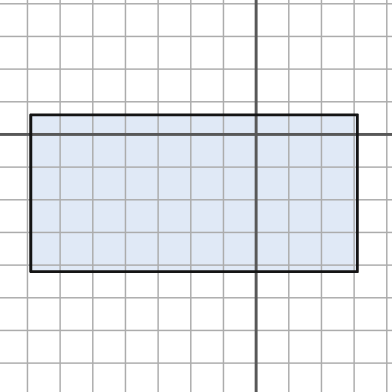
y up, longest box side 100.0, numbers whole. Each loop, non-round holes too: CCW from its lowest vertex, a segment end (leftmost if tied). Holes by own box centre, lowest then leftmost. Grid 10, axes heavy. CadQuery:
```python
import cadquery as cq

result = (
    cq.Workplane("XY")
    .moveTo(-69.0, -42.0)
    .lineTo(31.0, -42.0)
    .lineTo(31.0, 6.0)
    .lineTo(-69.0, 6.0)
    .close()
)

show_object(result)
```